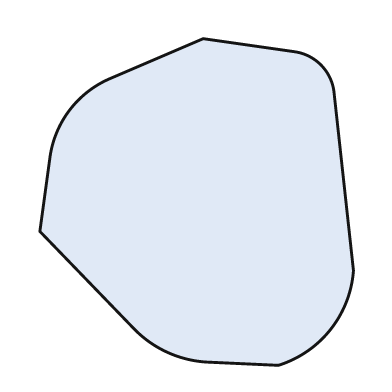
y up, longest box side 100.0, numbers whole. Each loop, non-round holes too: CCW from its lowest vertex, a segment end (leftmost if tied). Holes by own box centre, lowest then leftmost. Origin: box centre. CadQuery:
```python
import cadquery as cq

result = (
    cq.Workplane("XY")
    .moveTo(25.0, -50.0)
    .threePointArc((41.0, -39.0), (48.0, -21.0))
    .lineTo(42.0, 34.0)
    .threePointArc((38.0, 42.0), (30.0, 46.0))
    .lineTo(2.0, 50.0)
    .lineTo(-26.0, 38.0)
    .threePointArc((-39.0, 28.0), (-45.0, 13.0))
    .lineTo(-48.0, -9.0)
    .lineTo(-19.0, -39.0)
    .threePointArc((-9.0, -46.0), (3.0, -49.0))
    .close()
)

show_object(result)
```